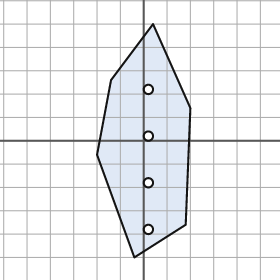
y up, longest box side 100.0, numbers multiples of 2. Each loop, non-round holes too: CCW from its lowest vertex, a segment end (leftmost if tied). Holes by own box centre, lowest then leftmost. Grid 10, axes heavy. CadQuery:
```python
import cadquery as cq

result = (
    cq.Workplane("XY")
    .moveTo(-4.0, -50.0)
    .lineTo(18.0, -36.0)
    .lineTo(20.0, 14.0)
    .lineTo(4.0, 50.0)
    .lineTo(-14.0, 26.0)
    .lineTo(-20.0, -6.0)
    .close()
    .moveTo(2.0, -38.0)
    .circle(2.0)
    .moveTo(2.0, -18.0)
    .circle(2.0)
    .moveTo(2.0, 2.0)
    .circle(2.0)
    .moveTo(2.0, 22.0)
    .circle(2.0)
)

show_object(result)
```